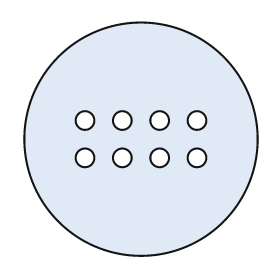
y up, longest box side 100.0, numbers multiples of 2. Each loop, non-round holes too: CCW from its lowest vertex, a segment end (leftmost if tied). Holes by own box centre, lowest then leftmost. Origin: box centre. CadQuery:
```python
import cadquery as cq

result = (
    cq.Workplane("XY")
    .moveTo(0.0, 0.0)
    .circle(50.0)
    .moveTo(-24.0, -8.0)
    .circle(4.0)
    .moveTo(-8.0, -8.0)
    .circle(4.0)
    .moveTo(8.0, -8.0)
    .circle(4.0)
    .moveTo(24.0, -8.0)
    .circle(4.0)
    .moveTo(-24.0, 8.0)
    .circle(4.0)
    .moveTo(-8.0, 8.0)
    .circle(4.0)
    .moveTo(8.0, 8.0)
    .circle(4.0)
    .moveTo(24.0, 8.0)
    .circle(4.0)
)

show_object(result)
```